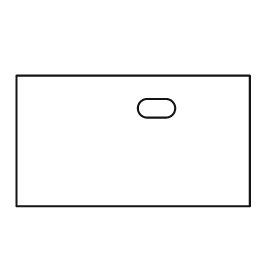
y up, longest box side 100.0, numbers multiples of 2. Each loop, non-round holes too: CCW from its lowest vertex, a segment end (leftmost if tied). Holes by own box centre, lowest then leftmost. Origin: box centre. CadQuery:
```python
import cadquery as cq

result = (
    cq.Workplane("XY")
    .moveTo(-50.0, -28.0)
    .lineTo(50.0, -28.0)
    .lineTo(50.0, 28.0)
    .lineTo(-50.0, 28.0)
    .close()
    .moveTo(6.0, 10.0)
    .lineTo(14.0, 10.0)
    .threePointArc((18.0, 14.0), (14.0, 18.0))
    .lineTo(6.0, 18.0)
    .threePointArc((2.0, 14.0), (6.0, 10.0))
    .close()
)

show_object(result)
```